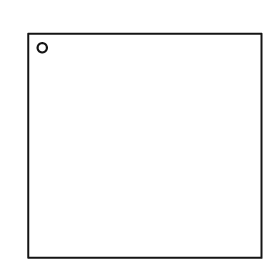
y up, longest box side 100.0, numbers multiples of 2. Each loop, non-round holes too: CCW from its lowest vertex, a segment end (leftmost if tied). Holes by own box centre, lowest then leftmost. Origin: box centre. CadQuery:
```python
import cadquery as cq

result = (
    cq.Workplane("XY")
    .moveTo(-50.0, -48.0)
    .lineTo(50.0, -48.0)
    .lineTo(50.0, 48.0)
    .lineTo(-50.0, 48.0)
    .close()
    .moveTo(-44.0, 42.0)
    .circle(2.0)
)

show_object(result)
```